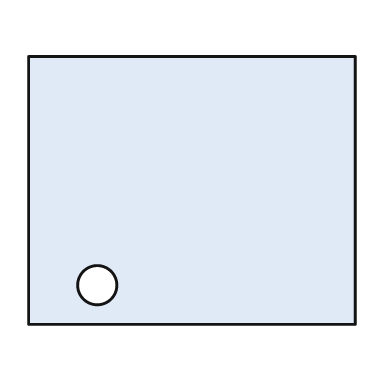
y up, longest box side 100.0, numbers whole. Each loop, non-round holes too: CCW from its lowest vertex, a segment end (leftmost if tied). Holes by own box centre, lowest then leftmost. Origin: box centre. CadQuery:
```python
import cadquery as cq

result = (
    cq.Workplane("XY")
    .moveTo(-50.0, -41.0)
    .lineTo(50.0, -41.0)
    .lineTo(50.0, 41.0)
    .lineTo(-50.0, 41.0)
    .close()
    .moveTo(-29.0, -29.0)
    .circle(6.0)
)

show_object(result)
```